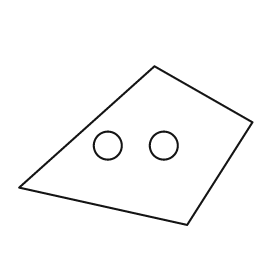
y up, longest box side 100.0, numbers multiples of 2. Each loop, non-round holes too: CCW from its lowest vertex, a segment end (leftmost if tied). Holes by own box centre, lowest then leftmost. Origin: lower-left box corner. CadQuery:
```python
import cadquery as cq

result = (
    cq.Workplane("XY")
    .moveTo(72.0, 0.0)
    .lineTo(100.0, 44.0)
    .lineTo(58.0, 68.0)
    .lineTo(0.0, 16.0)
    .close()
    .moveTo(38.0, 34.0)
    .circle(6.0)
    .moveTo(62.0, 34.0)
    .circle(6.0)
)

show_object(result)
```